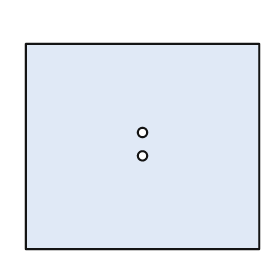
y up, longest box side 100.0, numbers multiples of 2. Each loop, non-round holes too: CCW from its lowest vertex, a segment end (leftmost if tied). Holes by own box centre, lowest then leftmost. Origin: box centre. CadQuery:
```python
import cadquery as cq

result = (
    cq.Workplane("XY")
    .moveTo(-50.0, -44.0)
    .lineTo(50.0, -44.0)
    .lineTo(50.0, 44.0)
    .lineTo(-50.0, 44.0)
    .close()
    .moveTo(0.0, -4.0)
    .circle(2.0)
    .moveTo(0.0, 6.0)
    .circle(2.0)
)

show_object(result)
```